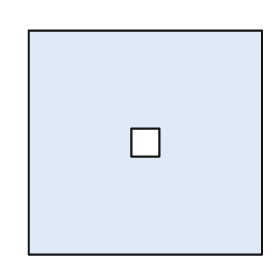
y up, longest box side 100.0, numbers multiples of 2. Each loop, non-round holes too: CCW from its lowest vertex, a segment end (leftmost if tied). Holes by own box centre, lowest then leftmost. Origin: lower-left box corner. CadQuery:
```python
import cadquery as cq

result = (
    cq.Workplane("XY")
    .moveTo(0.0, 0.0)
    .lineTo(100.0, 0.0)
    .lineTo(100.0, 96.0)
    .lineTo(0.0, 96.0)
    .close()
    .moveTo(44.0, 42.0)
    .lineTo(56.0, 42.0)
    .lineTo(56.0, 54.0)
    .lineTo(44.0, 54.0)
    .close()
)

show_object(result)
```